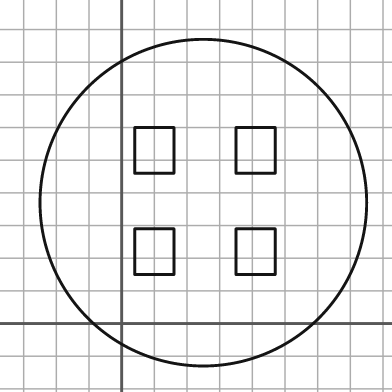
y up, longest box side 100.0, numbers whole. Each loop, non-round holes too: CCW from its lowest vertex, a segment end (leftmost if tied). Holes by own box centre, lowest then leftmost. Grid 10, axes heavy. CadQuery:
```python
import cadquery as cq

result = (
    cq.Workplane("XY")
    .moveTo(25.0, 37.0)
    .circle(50.0)
    .moveTo(4.0, 15.0)
    .lineTo(16.0, 15.0)
    .lineTo(16.0, 29.0)
    .lineTo(4.0, 29.0)
    .close()
    .moveTo(35.0, 15.0)
    .lineTo(47.0, 15.0)
    .lineTo(47.0, 29.0)
    .lineTo(35.0, 29.0)
    .close()
    .moveTo(4.0, 46.0)
    .lineTo(16.0, 46.0)
    .lineTo(16.0, 60.0)
    .lineTo(4.0, 60.0)
    .close()
    .moveTo(35.0, 46.0)
    .lineTo(47.0, 46.0)
    .lineTo(47.0, 60.0)
    .lineTo(35.0, 60.0)
    .close()
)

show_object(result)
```